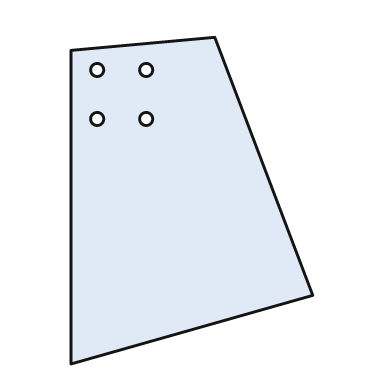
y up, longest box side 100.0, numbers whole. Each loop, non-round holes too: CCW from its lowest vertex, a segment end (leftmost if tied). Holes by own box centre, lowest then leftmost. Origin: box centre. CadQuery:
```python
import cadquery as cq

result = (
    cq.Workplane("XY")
    .moveTo(-37.0, -50.0)
    .lineTo(37.0, -29.0)
    .lineTo(7.0, 50.0)
    .lineTo(-37.0, 46.0)
    .close()
    .moveTo(-29.0, 25.0)
    .circle(2.0)
    .moveTo(-14.0, 25.0)
    .circle(2.0)
    .moveTo(-29.0, 40.0)
    .circle(2.0)
    .moveTo(-14.0, 40.0)
    .circle(2.0)
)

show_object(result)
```